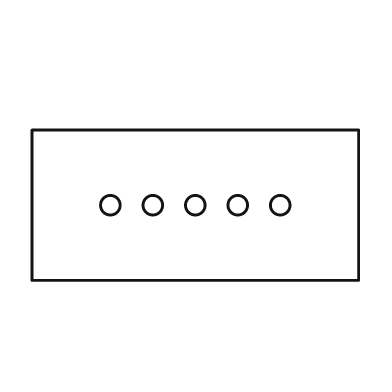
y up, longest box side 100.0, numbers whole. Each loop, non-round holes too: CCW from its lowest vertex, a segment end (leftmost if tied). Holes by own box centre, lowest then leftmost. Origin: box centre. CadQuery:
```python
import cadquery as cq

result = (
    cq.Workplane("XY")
    .moveTo(-50.0, -23.0)
    .lineTo(50.0, -23.0)
    .lineTo(50.0, 23.0)
    .lineTo(-50.0, 23.0)
    .close()
    .moveTo(-26.0, 0.0)
    .circle(3.0)
    .moveTo(-13.0, 0.0)
    .circle(3.0)
    .moveTo(0.0, 0.0)
    .circle(3.0)
    .moveTo(13.0, 0.0)
    .circle(3.0)
    .moveTo(26.0, 0.0)
    .circle(3.0)
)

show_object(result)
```